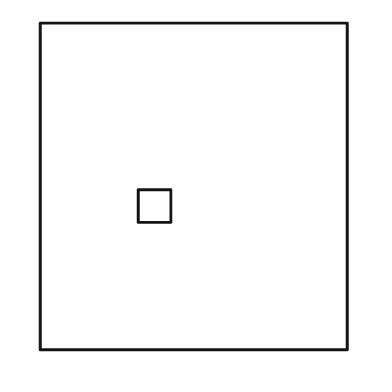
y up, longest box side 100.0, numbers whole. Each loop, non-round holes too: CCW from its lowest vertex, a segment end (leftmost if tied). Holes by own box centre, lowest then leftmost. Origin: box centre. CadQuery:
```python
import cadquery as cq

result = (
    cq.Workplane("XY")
    .moveTo(-47.0, -50.0)
    .lineTo(47.0, -50.0)
    .lineTo(47.0, 50.0)
    .lineTo(-47.0, 50.0)
    .close()
    .moveTo(-17.0, -11.0)
    .lineTo(-7.0, -11.0)
    .lineTo(-7.0, -1.0)
    .lineTo(-17.0, -1.0)
    .close()
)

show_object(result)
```